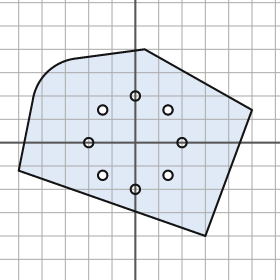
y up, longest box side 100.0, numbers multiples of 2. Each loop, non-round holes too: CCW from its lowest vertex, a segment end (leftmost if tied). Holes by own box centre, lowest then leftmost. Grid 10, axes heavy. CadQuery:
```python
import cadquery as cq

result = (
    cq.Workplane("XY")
    .moveTo(30.0, -40.0)
    .lineTo(50.0, 14.0)
    .lineTo(4.0, 40.0)
    .lineTo(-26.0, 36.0)
    .threePointArc((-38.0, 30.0), (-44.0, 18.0))
    .lineTo(-50.0, -12.0)
    .close()
    .moveTo(0.0, -20.0)
    .circle(2.0)
    .moveTo(-14.0, -14.0)
    .circle(2.0)
    .moveTo(14.0, -14.0)
    .circle(2.0)
    .moveTo(-20.0, 0.0)
    .circle(2.0)
    .moveTo(20.0, 0.0)
    .circle(2.0)
    .moveTo(-14.0, 14.0)
    .circle(2.0)
    .moveTo(14.0, 14.0)
    .circle(2.0)
    .moveTo(0.0, 20.0)
    .circle(2.0)
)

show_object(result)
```